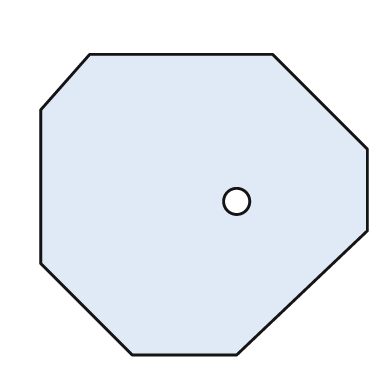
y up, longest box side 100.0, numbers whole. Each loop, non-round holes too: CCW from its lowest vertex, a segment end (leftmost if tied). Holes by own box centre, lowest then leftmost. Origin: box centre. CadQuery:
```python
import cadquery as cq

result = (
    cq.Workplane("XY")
    .moveTo(-22.0, -46.0)
    .lineTo(10.0, -46.0)
    .lineTo(50.0, -8.0)
    .lineTo(50.0, 17.0)
    .lineTo(21.0, 46.0)
    .lineTo(-35.0, 46.0)
    .lineTo(-50.0, 29.0)
    .lineTo(-50.0, -18.0)
    .close()
    .moveTo(10.0, 1.0)
    .circle(4.0)
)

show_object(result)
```